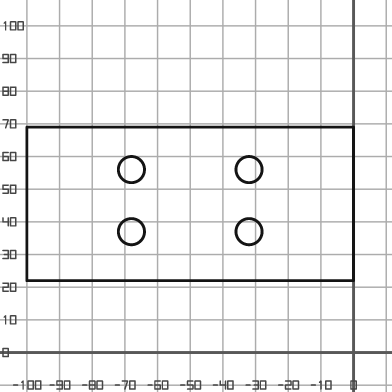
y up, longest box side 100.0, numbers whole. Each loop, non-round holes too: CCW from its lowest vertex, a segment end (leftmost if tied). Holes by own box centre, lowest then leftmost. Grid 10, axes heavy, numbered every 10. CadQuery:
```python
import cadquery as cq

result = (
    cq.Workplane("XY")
    .moveTo(-100.0, 22.0)
    .lineTo(0.0, 22.0)
    .lineTo(0.0, 69.0)
    .lineTo(-100.0, 69.0)
    .close()
    .moveTo(-68.0, 37.0)
    .circle(4.0)
    .moveTo(-32.0, 37.0)
    .circle(4.0)
    .moveTo(-68.0, 56.0)
    .circle(4.0)
    .moveTo(-32.0, 56.0)
    .circle(4.0)
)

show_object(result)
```